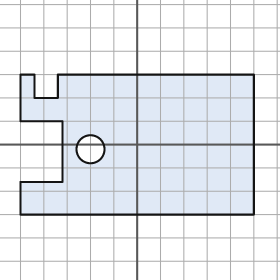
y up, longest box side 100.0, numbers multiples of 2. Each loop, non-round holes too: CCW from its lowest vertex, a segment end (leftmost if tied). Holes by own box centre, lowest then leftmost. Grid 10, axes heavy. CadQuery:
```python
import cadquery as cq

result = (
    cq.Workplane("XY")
    .moveTo(-50.0, -30.0)
    .lineTo(50.0, -30.0)
    .lineTo(50.0, 30.0)
    .lineTo(-34.0, 30.0)
    .lineTo(-34.0, 20.0)
    .lineTo(-44.0, 20.0)
    .lineTo(-44.0, 30.0)
    .lineTo(-50.0, 30.0)
    .lineTo(-50.0, 10.0)
    .lineTo(-32.0, 10.0)
    .lineTo(-32.0, -16.0)
    .lineTo(-50.0, -16.0)
    .close()
    .moveTo(-20.0, -2.0)
    .circle(6.0)
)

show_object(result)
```